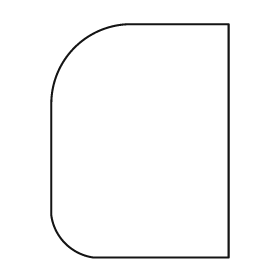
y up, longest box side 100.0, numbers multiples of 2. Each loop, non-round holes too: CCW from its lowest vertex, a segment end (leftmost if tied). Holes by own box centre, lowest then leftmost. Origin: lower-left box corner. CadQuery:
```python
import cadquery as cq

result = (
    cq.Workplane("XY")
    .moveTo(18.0, 0.0)
    .lineTo(76.0, 0.0)
    .lineTo(76.0, 100.0)
    .lineTo(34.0, 100.0)
    .threePointArc((10.0, 90.0), (0.0, 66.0))
    .lineTo(0.0, 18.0)
    .threePointArc((6.0, 6.0), (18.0, 0.0))
    .close()
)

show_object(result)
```